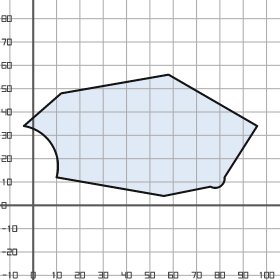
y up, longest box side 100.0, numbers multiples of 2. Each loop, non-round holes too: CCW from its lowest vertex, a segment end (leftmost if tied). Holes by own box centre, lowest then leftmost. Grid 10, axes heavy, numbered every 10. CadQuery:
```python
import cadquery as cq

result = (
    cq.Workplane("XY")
    .moveTo(56.0, 4.0)
    .lineTo(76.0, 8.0)
    .threePointArc((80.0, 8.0), (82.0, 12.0))
    .lineTo(96.0, 34.0)
    .lineTo(58.0, 56.0)
    .lineTo(12.0, 48.0)
    .lineTo(-4.0, 34.0)
    .threePointArc((8.0, 26.0), (10.0, 12.0))
    .close()
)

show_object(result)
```